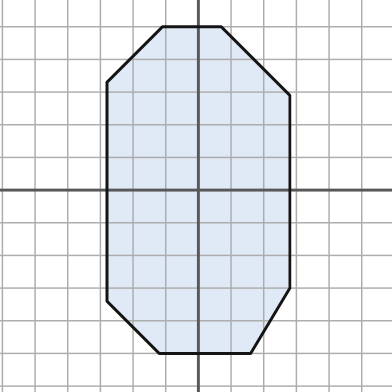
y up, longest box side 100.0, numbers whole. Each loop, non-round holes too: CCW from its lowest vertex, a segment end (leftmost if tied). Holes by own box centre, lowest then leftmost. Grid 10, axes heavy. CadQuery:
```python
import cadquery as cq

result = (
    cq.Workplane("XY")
    .moveTo(-12.0, -50.0)
    .lineTo(16.0, -50.0)
    .lineTo(28.0, -30.0)
    .lineTo(28.0, 29.0)
    .lineTo(7.0, 50.0)
    .lineTo(-11.0, 50.0)
    .lineTo(-28.0, 33.0)
    .lineTo(-28.0, -34.0)
    .close()
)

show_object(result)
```